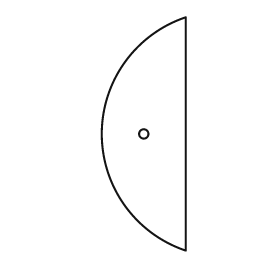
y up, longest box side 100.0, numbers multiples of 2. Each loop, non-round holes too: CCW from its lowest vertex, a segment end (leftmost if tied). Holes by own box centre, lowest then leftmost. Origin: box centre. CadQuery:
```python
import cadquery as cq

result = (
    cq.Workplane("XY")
    .moveTo(18.0, -50.0)
    .lineTo(18.0, 50.0)
    .threePointArc((-18.0, 0.0), (18.0, -50.0))
    .close()
    .moveTo(0.0, 0.0)
    .circle(2.0)
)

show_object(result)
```